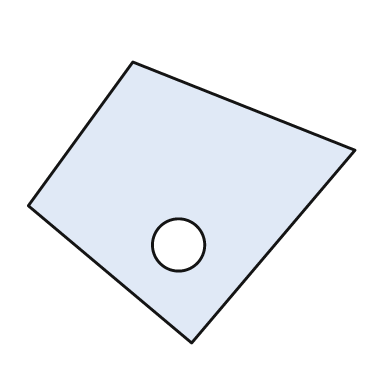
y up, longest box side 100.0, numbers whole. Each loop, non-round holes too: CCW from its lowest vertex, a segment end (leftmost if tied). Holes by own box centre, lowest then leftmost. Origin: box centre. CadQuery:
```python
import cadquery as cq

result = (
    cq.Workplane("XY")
    .moveTo(0.0, -43.0)
    .lineTo(50.0, 16.0)
    .lineTo(-18.0, 43.0)
    .lineTo(-50.0, -1.0)
    .close()
    .moveTo(-4.0, -13.0)
    .circle(8.0)
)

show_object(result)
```